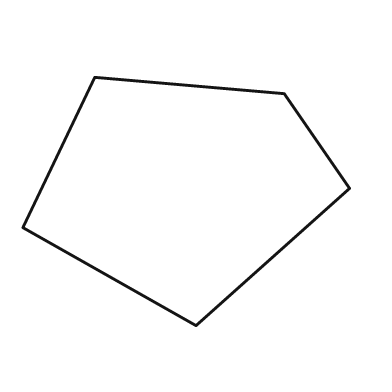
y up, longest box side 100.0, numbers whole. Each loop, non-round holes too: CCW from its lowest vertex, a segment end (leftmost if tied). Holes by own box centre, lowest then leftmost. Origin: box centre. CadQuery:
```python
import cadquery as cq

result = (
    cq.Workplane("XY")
    .moveTo(3.0, -38.0)
    .lineTo(50.0, 4.0)
    .lineTo(30.0, 33.0)
    .lineTo(-28.0, 38.0)
    .lineTo(-50.0, -8.0)
    .close()
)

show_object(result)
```